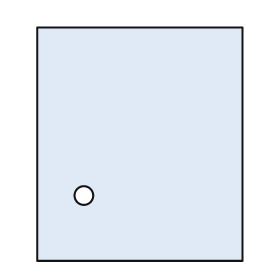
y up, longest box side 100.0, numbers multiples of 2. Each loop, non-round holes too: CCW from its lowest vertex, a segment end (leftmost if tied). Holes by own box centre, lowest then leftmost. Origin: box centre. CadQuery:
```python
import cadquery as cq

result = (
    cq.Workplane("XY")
    .moveTo(-44.0, -50.0)
    .lineTo(44.0, -50.0)
    .lineTo(44.0, 50.0)
    .lineTo(-44.0, 50.0)
    .close()
    .moveTo(-24.0, -22.0)
    .circle(4.0)
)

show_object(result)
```